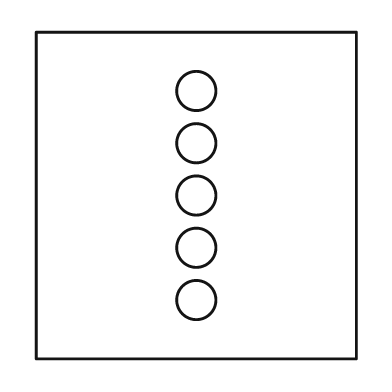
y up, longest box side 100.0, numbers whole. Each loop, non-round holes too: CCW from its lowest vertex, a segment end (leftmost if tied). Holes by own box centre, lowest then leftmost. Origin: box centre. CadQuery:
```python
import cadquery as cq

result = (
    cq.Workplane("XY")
    .moveTo(-49.0, -50.0)
    .lineTo(49.0, -50.0)
    .lineTo(49.0, 50.0)
    .lineTo(-49.0, 50.0)
    .close()
    .moveTo(0.0, -32.0)
    .circle(6.0)
    .moveTo(0.0, -16.0)
    .circle(6.0)
    .moveTo(0.0, 0.0)
    .circle(6.0)
    .moveTo(0.0, 16.0)
    .circle(6.0)
    .moveTo(0.0, 32.0)
    .circle(6.0)
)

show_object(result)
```